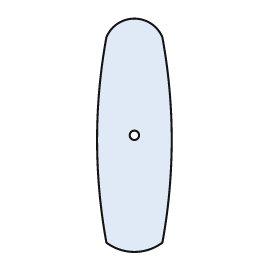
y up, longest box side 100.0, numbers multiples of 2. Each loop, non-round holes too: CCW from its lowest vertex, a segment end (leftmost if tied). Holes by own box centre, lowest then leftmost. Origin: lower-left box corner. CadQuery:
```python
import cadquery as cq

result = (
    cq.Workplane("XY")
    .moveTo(4.0, 4.0)
    .threePointArc((16.0, 0.0), (28.0, 4.0))
    .threePointArc((32.0, 48.0), (28.0, 92.0))
    .threePointArc((16.0, 100.0), (4.0, 92.0))
    .threePointArc((0.0, 48.0), (4.0, 4.0))
    .close()
    .moveTo(16.0, 50.0)
    .circle(2.0)
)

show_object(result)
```